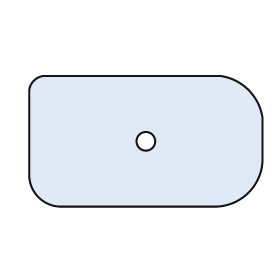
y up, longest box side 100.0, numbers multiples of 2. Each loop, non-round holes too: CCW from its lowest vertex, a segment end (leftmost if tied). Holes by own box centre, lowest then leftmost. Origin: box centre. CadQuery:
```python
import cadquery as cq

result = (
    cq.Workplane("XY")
    .moveTo(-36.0, -28.0)
    .lineTo(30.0, -28.0)
    .threePointArc((44.0, -22.0), (50.0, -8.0))
    .lineTo(50.0, 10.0)
    .threePointArc((44.0, 22.0), (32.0, 28.0))
    .lineTo(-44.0, 28.0)
    .threePointArc((-48.0, 26.0), (-50.0, 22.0))
    .lineTo(-50.0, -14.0)
    .threePointArc((-46.0, -24.0), (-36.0, -28.0))
    .close()
    .moveTo(0.0, 0.0)
    .circle(4.0)
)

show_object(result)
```